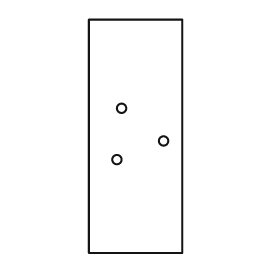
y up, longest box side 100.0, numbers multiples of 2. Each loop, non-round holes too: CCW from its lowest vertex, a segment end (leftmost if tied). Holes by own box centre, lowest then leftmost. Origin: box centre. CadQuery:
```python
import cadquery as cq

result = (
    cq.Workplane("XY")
    .moveTo(-20.0, -50.0)
    .lineTo(20.0, -50.0)
    .lineTo(20.0, 50.0)
    .lineTo(-20.0, 50.0)
    .close()
    .moveTo(-8.0, -10.0)
    .circle(2.0)
    .moveTo(12.0, -2.0)
    .circle(2.0)
    .moveTo(-6.0, 12.0)
    .circle(2.0)
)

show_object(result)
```